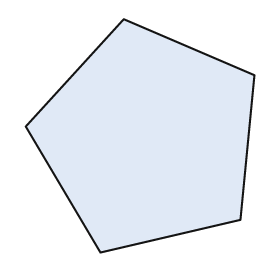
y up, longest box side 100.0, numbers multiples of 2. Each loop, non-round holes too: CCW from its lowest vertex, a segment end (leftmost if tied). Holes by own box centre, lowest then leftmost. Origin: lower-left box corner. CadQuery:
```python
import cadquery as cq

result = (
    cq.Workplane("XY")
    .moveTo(32.0, 0.0)
    .lineTo(92.0, 14.0)
    .lineTo(98.0, 76.0)
    .lineTo(42.0, 100.0)
    .lineTo(0.0, 54.0)
    .close()
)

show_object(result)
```